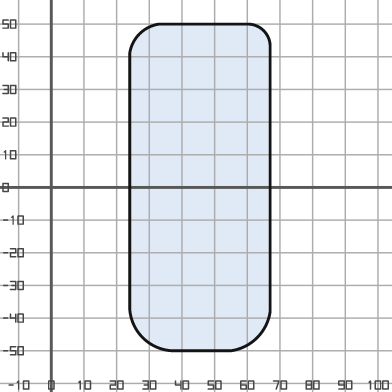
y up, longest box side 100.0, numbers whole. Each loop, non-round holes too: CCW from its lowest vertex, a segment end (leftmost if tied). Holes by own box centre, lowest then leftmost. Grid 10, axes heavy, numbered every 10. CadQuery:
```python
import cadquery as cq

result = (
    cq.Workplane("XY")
    .moveTo(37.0, -50.0)
    .lineTo(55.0, -50.0)
    .threePointArc((63.0, -46.0), (67.0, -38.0))
    .lineTo(67.0, 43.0)
    .threePointArc((65.0, 48.0), (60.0, 50.0))
    .lineTo(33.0, 50.0)
    .threePointArc((27.0, 47.0), (24.0, 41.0))
    .lineTo(24.0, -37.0)
    .threePointArc((28.0, -46.0), (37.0, -50.0))
    .close()
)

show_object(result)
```